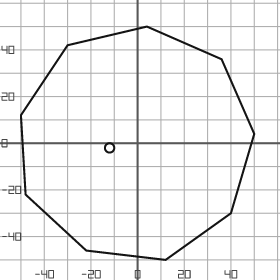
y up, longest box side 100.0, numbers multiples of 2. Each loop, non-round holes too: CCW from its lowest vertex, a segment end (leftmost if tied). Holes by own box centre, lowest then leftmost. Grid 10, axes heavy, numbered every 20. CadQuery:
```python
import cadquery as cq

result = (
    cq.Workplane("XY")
    .moveTo(12.0, -50.0)
    .lineTo(40.0, -30.0)
    .lineTo(50.0, 4.0)
    .lineTo(36.0, 36.0)
    .lineTo(4.0, 50.0)
    .lineTo(-30.0, 42.0)
    .lineTo(-50.0, 12.0)
    .lineTo(-48.0, -22.0)
    .lineTo(-22.0, -46.0)
    .close()
    .moveTo(-12.0, -2.0)
    .circle(2.0)
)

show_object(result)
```